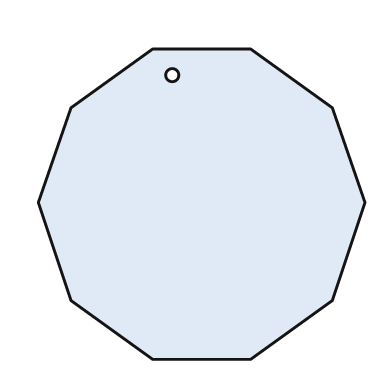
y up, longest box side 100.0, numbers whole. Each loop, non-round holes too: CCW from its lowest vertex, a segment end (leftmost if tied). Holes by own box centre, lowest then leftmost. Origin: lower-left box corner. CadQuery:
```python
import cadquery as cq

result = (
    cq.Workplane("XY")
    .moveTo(35.0, 0.0)
    .lineTo(65.0, 0.0)
    .lineTo(90.0, 18.0)
    .lineTo(100.0, 48.0)
    .lineTo(90.0, 77.0)
    .lineTo(65.0, 95.0)
    .lineTo(35.0, 95.0)
    .lineTo(10.0, 77.0)
    .lineTo(0.0, 48.0)
    .lineTo(10.0, 18.0)
    .close()
    .moveTo(41.0, 87.0)
    .circle(2.0)
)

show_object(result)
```